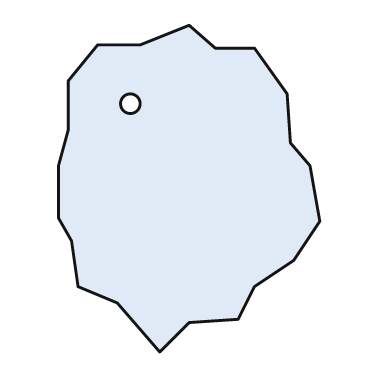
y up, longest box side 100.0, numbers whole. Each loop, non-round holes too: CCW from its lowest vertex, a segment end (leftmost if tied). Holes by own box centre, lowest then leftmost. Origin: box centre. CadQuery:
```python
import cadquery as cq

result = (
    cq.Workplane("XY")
    .moveTo(-9.0, -50.0)
    .lineTo(0.0, -41.0)
    .lineTo(15.0, -40.0)
    .lineTo(20.0, -30.0)
    .lineTo(32.0, -22.0)
    .lineTo(40.0, -10.0)
    .lineTo(37.0, 7.0)
    .lineTo(31.0, 14.0)
    .lineTo(30.0, 29.0)
    .lineTo(20.0, 43.0)
    .lineTo(8.0, 43.0)
    .lineTo(0.0, 50.0)
    .lineTo(-15.0, 44.0)
    .lineTo(-28.0, 44.0)
    .lineTo(-37.0, 33.0)
    .lineTo(-37.0, 18.0)
    .lineTo(-40.0, 7.0)
    .lineTo(-40.0, -9.0)
    .lineTo(-36.0, -16.0)
    .lineTo(-34.0, -30.0)
    .lineTo(-22.0, -35.0)
    .close()
    .moveTo(-18.0, 26.0)
    .circle(3.0)
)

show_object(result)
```